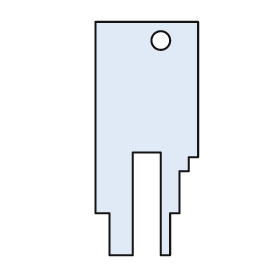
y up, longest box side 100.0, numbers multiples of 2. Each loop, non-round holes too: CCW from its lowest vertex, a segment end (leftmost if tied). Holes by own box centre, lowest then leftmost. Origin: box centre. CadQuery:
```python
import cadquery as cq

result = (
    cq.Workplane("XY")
    .moveTo(-16.0, -50.0)
    .lineTo(-6.0, -50.0)
    .lineTo(-6.0, -6.0)
    .lineTo(6.0, -6.0)
    .lineTo(6.0, -50.0)
    .lineTo(10.0, -50.0)
    .lineTo(10.0, -32.0)
    .lineTo(14.0, -32.0)
    .lineTo(14.0, -14.0)
    .lineTo(18.0, -14.0)
    .lineTo(18.0, -8.0)
    .lineTo(22.0, -8.0)
    .lineTo(22.0, 50.0)
    .lineTo(-22.0, 50.0)
    .lineTo(-22.0, -32.0)
    .lineTo(-16.0, -32.0)
    .close()
    .moveTo(6.0, 42.0)
    .circle(4.0)
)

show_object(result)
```